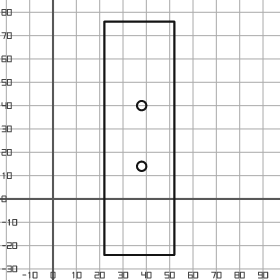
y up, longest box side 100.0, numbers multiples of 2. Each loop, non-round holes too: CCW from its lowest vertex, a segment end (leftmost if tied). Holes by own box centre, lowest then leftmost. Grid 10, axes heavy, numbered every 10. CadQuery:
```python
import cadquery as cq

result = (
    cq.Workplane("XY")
    .moveTo(22.0, -24.0)
    .lineTo(52.0, -24.0)
    .lineTo(52.0, 76.0)
    .lineTo(22.0, 76.0)
    .close()
    .moveTo(38.0, 14.0)
    .circle(2.0)
    .moveTo(38.0, 40.0)
    .circle(2.0)
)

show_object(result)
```